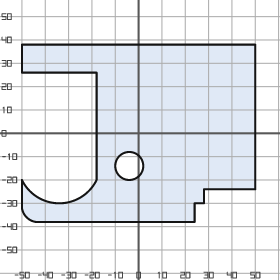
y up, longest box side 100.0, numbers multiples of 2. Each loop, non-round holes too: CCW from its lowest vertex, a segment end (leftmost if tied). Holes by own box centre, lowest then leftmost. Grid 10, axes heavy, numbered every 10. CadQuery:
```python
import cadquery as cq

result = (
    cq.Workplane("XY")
    .moveTo(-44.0, -38.0)
    .lineTo(24.0, -38.0)
    .lineTo(24.0, -30.0)
    .lineTo(28.0, -30.0)
    .lineTo(28.0, -24.0)
    .lineTo(50.0, -24.0)
    .lineTo(50.0, 38.0)
    .lineTo(-50.0, 38.0)
    .lineTo(-50.0, 26.0)
    .lineTo(-18.0, 26.0)
    .lineTo(-18.0, -20.0)
    .threePointArc((-34.0, -30.0), (-50.0, -20.0))
    .lineTo(-50.0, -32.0)
    .threePointArc((-48.0, -36.0), (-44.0, -38.0))
    .close()
    .moveTo(-4.0, -14.0)
    .circle(6.0)
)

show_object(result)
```